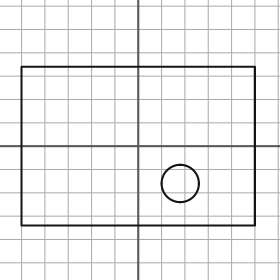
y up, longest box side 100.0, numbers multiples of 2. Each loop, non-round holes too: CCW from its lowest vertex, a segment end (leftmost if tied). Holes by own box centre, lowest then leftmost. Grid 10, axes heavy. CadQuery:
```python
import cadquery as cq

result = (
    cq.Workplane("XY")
    .moveTo(-50.0, -34.0)
    .lineTo(50.0, -34.0)
    .lineTo(50.0, 34.0)
    .lineTo(-50.0, 34.0)
    .close()
    .moveTo(18.0, -16.0)
    .circle(8.0)
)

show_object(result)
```